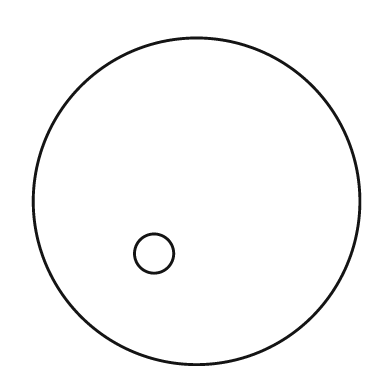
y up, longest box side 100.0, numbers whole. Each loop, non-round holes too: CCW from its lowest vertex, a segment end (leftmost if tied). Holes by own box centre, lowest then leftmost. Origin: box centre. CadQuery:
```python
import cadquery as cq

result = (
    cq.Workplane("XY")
    .moveTo(0.0, 0.0)
    .circle(50.0)
    .moveTo(-13.0, -16.0)
    .circle(6.0)
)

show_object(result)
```